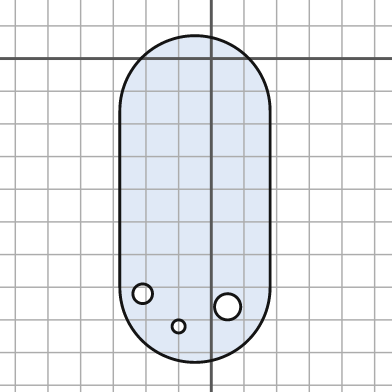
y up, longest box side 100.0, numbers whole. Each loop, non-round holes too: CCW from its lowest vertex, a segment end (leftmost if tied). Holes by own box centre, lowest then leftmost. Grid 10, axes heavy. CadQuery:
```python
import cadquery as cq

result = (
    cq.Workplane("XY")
    .moveTo(-28.0, -70.0)
    .threePointArc((-5.0, -93.0), (18.0, -70.0))
    .lineTo(18.0, -16.0)
    .threePointArc((-5.0, 7.0), (-28.0, -16.0))
    .close()
    .moveTo(-10.0, -82.0)
    .circle(2.0)
    .moveTo(5.0, -76.0)
    .circle(4.0)
    .moveTo(-21.0, -72.0)
    .circle(3.0)
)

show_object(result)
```